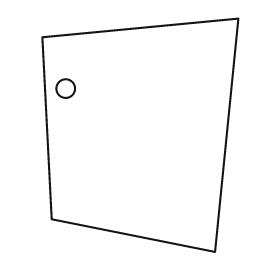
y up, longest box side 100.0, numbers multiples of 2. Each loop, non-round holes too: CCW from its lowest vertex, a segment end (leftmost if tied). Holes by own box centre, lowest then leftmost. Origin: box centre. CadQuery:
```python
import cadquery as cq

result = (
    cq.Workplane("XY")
    .moveTo(32.0, -50.0)
    .lineTo(42.0, 50.0)
    .lineTo(-42.0, 42.0)
    .lineTo(-38.0, -36.0)
    .close()
    .moveTo(-32.0, 20.0)
    .circle(4.0)
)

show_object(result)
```